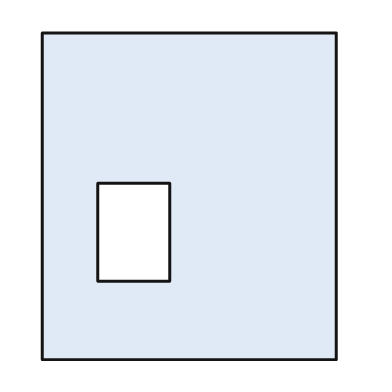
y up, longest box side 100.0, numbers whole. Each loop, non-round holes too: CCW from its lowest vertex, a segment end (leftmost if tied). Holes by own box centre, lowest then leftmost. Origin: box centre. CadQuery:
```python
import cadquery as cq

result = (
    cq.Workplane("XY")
    .moveTo(-45.0, -50.0)
    .lineTo(45.0, -50.0)
    .lineTo(45.0, 50.0)
    .lineTo(-45.0, 50.0)
    .close()
    .moveTo(-28.0, -26.0)
    .lineTo(-6.0, -26.0)
    .lineTo(-6.0, 4.0)
    .lineTo(-28.0, 4.0)
    .close()
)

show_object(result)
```